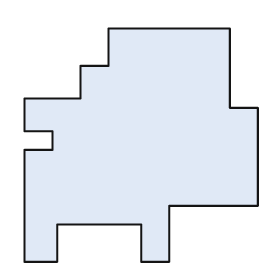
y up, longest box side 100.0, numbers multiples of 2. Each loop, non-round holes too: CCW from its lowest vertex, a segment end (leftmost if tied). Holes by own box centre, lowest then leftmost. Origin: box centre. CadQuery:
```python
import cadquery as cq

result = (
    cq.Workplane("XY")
    .moveTo(-50.0, -50.0)
    .lineTo(-36.0, -50.0)
    .lineTo(-36.0, -34.0)
    .lineTo(0.0, -34.0)
    .lineTo(0.0, -50.0)
    .lineTo(12.0, -50.0)
    .lineTo(12.0, -26.0)
    .lineTo(50.0, -26.0)
    .lineTo(50.0, 16.0)
    .lineTo(38.0, 16.0)
    .lineTo(38.0, 50.0)
    .lineTo(-14.0, 50.0)
    .lineTo(-14.0, 34.0)
    .lineTo(-26.0, 34.0)
    .lineTo(-26.0, 20.0)
    .lineTo(-50.0, 20.0)
    .lineTo(-50.0, 6.0)
    .lineTo(-38.0, 6.0)
    .lineTo(-38.0, -2.0)
    .lineTo(-50.0, -2.0)
    .close()
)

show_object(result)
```